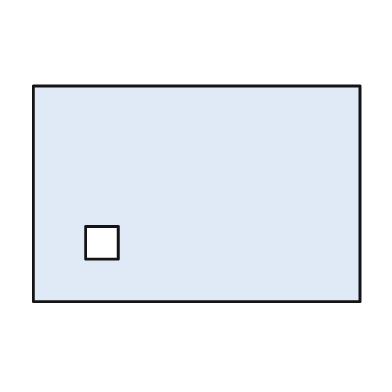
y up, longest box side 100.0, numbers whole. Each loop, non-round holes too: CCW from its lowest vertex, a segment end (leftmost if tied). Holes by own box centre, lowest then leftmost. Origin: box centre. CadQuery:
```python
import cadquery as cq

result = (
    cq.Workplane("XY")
    .moveTo(-50.0, -33.0)
    .lineTo(50.0, -33.0)
    .lineTo(50.0, 33.0)
    .lineTo(-50.0, 33.0)
    .close()
    .moveTo(-34.0, -20.0)
    .lineTo(-24.0, -20.0)
    .lineTo(-24.0, -10.0)
    .lineTo(-34.0, -10.0)
    .close()
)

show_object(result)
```